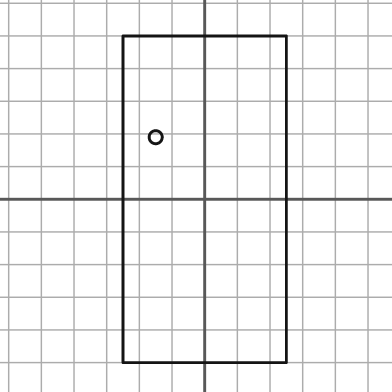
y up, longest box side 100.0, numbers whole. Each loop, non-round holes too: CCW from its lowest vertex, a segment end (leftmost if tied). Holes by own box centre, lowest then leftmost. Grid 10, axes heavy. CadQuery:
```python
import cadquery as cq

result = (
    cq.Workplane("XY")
    .moveTo(-25.0, -50.0)
    .lineTo(25.0, -50.0)
    .lineTo(25.0, 50.0)
    .lineTo(-25.0, 50.0)
    .close()
    .moveTo(-15.0, 19.0)
    .circle(2.0)
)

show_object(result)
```